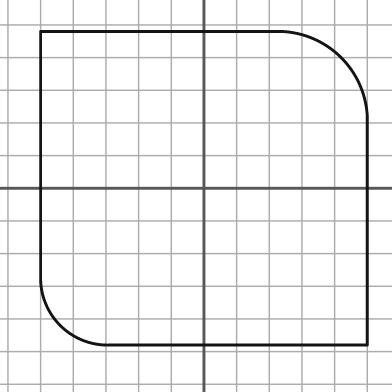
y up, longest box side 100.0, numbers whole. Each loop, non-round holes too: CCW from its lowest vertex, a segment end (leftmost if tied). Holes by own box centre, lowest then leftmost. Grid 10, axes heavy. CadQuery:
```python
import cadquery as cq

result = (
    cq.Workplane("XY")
    .moveTo(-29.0, -48.0)
    .lineTo(50.0, -48.0)
    .lineTo(50.0, 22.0)
    .threePointArc((42.0, 40.0), (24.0, 48.0))
    .lineTo(-50.0, 48.0)
    .lineTo(-50.0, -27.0)
    .threePointArc((-44.0, -42.0), (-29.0, -48.0))
    .close()
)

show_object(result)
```